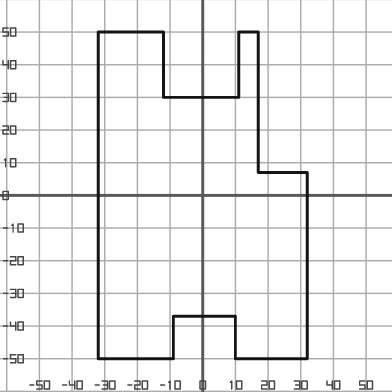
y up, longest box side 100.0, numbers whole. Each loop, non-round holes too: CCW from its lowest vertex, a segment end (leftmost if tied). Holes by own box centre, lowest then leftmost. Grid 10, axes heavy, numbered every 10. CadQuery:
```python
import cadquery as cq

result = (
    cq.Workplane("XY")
    .moveTo(-32.0, -50.0)
    .lineTo(-9.0, -50.0)
    .lineTo(-9.0, -37.0)
    .lineTo(10.0, -37.0)
    .lineTo(10.0, -50.0)
    .lineTo(32.0, -50.0)
    .lineTo(32.0, 7.0)
    .lineTo(17.0, 7.0)
    .lineTo(17.0, 50.0)
    .lineTo(11.0, 50.0)
    .lineTo(11.0, 30.0)
    .lineTo(-12.0, 30.0)
    .lineTo(-12.0, 50.0)
    .lineTo(-32.0, 50.0)
    .close()
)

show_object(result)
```